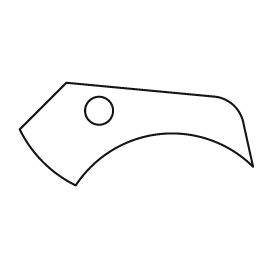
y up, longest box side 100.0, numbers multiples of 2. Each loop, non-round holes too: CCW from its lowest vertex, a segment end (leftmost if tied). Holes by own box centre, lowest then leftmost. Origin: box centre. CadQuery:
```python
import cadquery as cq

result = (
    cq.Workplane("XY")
    .moveTo(-26.0, -22.0)
    .threePointArc((10.0, 0.0), (50.0, -14.0))
    .lineTo(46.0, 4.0)
    .threePointArc((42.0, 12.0), (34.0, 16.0))
    .lineTo(-30.0, 22.0)
    .lineTo(-50.0, 2.0)
    .threePointArc((-40.0, -12.0), (-26.0, -22.0))
    .close()
    .moveTo(-16.0, 10.0)
    .circle(6.0)
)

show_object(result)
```